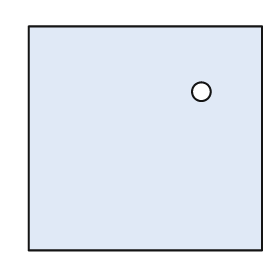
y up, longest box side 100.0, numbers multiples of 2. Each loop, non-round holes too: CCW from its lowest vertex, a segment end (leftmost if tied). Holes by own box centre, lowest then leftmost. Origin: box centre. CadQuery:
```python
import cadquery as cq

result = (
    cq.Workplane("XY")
    .moveTo(-50.0, -48.0)
    .lineTo(50.0, -48.0)
    .lineTo(50.0, 48.0)
    .lineTo(-50.0, 48.0)
    .close()
    .moveTo(24.0, 20.0)
    .circle(4.0)
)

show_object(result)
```